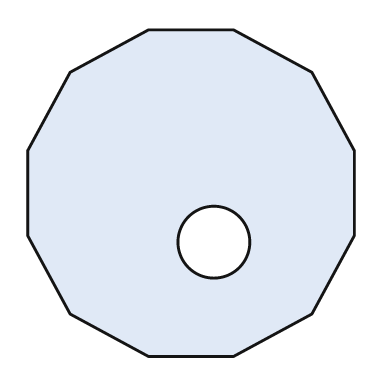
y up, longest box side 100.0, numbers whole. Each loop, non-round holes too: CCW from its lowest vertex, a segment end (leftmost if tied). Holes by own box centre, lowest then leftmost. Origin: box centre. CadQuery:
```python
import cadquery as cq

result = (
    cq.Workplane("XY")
    .moveTo(-13.0, -50.0)
    .lineTo(13.0, -50.0)
    .lineTo(37.0, -37.0)
    .lineTo(50.0, -13.0)
    .lineTo(50.0, 13.0)
    .lineTo(37.0, 37.0)
    .lineTo(13.0, 50.0)
    .lineTo(-13.0, 50.0)
    .lineTo(-37.0, 37.0)
    .lineTo(-50.0, 13.0)
    .lineTo(-50.0, -13.0)
    .lineTo(-37.0, -37.0)
    .close()
    .moveTo(7.0, -15.0)
    .circle(11.0)
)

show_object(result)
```